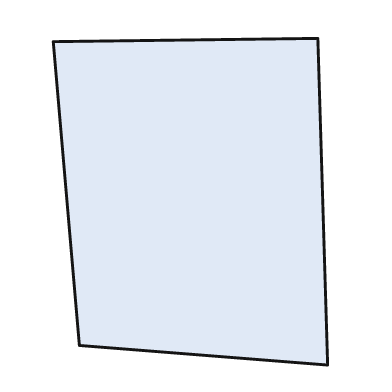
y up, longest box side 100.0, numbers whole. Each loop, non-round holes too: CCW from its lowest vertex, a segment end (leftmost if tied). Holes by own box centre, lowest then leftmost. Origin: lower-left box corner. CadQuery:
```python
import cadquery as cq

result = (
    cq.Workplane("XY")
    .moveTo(84.0, 0.0)
    .lineTo(81.0, 100.0)
    .lineTo(0.0, 99.0)
    .lineTo(8.0, 6.0)
    .close()
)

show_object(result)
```